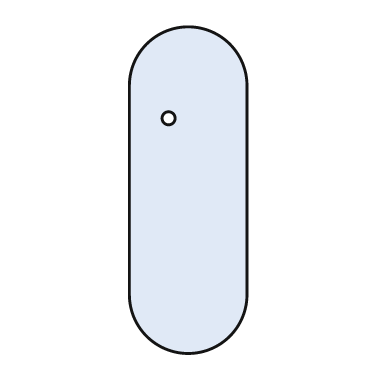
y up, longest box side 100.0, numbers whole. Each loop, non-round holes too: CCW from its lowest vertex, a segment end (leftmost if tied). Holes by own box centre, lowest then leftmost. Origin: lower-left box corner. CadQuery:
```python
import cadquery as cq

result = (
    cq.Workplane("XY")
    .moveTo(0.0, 18.0)
    .threePointArc((18.0, 0.0), (36.0, 18.0))
    .lineTo(36.0, 82.0)
    .threePointArc((18.0, 100.0), (0.0, 82.0))
    .close()
    .moveTo(12.0, 72.0)
    .circle(2.0)
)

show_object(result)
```